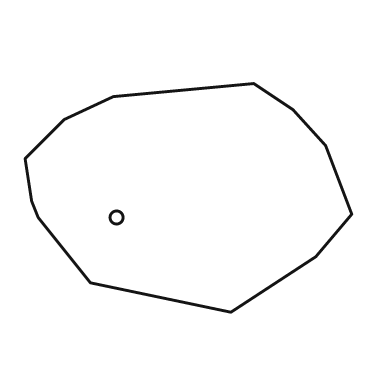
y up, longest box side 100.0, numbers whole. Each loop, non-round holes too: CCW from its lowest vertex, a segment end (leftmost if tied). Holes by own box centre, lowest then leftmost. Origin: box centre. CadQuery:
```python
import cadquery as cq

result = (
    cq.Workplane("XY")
    .moveTo(13.0, -35.0)
    .lineTo(39.0, -18.0)
    .lineTo(50.0, -5.0)
    .lineTo(42.0, 16.0)
    .lineTo(32.0, 27.0)
    .lineTo(20.0, 35.0)
    .lineTo(-23.0, 31.0)
    .lineTo(-38.0, 24.0)
    .lineTo(-50.0, 12.0)
    .lineTo(-48.0, -1.0)
    .lineTo(-46.0, -6.0)
    .lineTo(-30.0, -26.0)
    .close()
    .moveTo(-22.0, -6.0)
    .circle(2.0)
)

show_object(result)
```